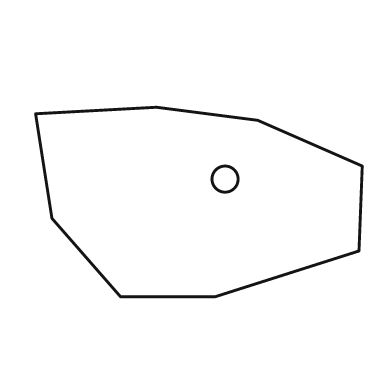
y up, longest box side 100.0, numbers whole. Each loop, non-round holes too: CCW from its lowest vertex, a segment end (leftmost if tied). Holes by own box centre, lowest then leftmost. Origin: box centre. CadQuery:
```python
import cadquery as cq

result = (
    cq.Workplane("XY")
    .moveTo(-24.0, -29.0)
    .lineTo(5.0, -29.0)
    .lineTo(49.0, -15.0)
    .lineTo(50.0, 11.0)
    .lineTo(18.0, 25.0)
    .lineTo(-13.0, 29.0)
    .lineTo(-50.0, 27.0)
    .lineTo(-45.0, -5.0)
    .close()
    .moveTo(8.0, 7.0)
    .circle(4.0)
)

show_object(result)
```